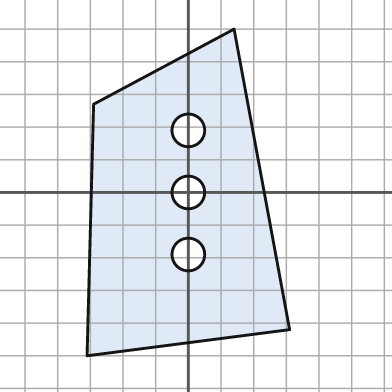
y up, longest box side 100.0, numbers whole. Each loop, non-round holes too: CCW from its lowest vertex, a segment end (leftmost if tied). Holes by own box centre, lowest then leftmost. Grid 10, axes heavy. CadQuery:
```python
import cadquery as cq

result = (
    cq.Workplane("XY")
    .moveTo(-31.0, -50.0)
    .lineTo(31.0, -42.0)
    .lineTo(14.0, 50.0)
    .lineTo(-29.0, 27.0)
    .close()
    .moveTo(0.0, -19.0)
    .circle(5.0)
    .moveTo(0.0, 0.0)
    .circle(5.0)
    .moveTo(0.0, 19.0)
    .circle(5.0)
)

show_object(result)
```